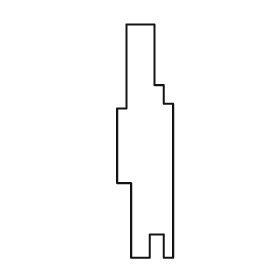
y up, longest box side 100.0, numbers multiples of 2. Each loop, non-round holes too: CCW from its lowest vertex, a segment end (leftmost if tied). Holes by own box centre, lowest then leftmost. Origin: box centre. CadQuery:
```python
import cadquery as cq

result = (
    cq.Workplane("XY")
    .moveTo(-6.0, -50.0)
    .lineTo(2.0, -50.0)
    .lineTo(2.0, -40.0)
    .lineTo(8.0, -40.0)
    .lineTo(8.0, -50.0)
    .lineTo(12.0, -50.0)
    .lineTo(12.0, 16.0)
    .lineTo(8.0, 16.0)
    .lineTo(8.0, 24.0)
    .lineTo(4.0, 24.0)
    .lineTo(4.0, 50.0)
    .lineTo(-8.0, 50.0)
    .lineTo(-8.0, 14.0)
    .lineTo(-12.0, 14.0)
    .lineTo(-12.0, -18.0)
    .lineTo(-6.0, -18.0)
    .close()
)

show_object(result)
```